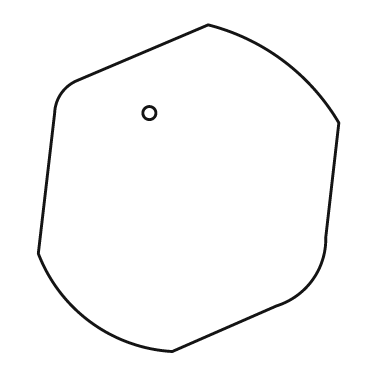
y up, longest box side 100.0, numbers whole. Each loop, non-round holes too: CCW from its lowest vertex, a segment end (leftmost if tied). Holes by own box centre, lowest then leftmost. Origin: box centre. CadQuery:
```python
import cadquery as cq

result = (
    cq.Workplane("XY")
    .moveTo(-5.0, -50.0)
    .lineTo(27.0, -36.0)
    .threePointArc((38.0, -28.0), (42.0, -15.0))
    .lineTo(46.0, 20.0)
    .threePointArc((29.0, 39.0), (6.0, 50.0))
    .lineTo(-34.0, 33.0)
    .threePointArc((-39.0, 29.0), (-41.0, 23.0))
    .lineTo(-46.0, -20.0)
    .threePointArc((-30.0, -41.0), (-5.0, -50.0))
    .close()
    .moveTo(-12.0, 23.0)
    .circle(2.0)
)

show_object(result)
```